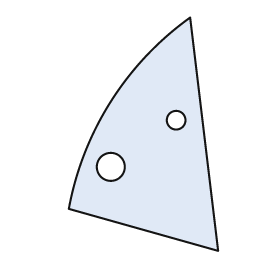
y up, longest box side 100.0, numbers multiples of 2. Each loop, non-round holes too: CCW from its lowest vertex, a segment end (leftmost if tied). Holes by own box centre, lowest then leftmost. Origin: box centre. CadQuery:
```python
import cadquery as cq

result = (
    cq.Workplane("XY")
    .moveTo(32.0, -50.0)
    .lineTo(20.0, 50.0)
    .threePointArc((-14.0, 14.0), (-32.0, -32.0))
    .close()
    .moveTo(-14.0, -14.0)
    .circle(6.0)
    .moveTo(14.0, 6.0)
    .circle(4.0)
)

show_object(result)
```